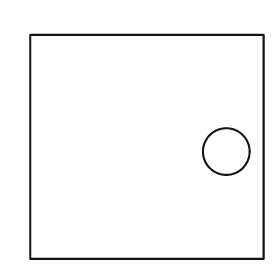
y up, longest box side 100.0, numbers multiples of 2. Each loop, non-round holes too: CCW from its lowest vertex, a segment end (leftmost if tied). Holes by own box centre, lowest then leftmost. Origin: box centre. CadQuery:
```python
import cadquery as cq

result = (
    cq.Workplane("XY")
    .moveTo(-50.0, -48.0)
    .lineTo(50.0, -48.0)
    .lineTo(50.0, 48.0)
    .lineTo(-50.0, 48.0)
    .close()
    .moveTo(34.0, -2.0)
    .circle(10.0)
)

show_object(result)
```